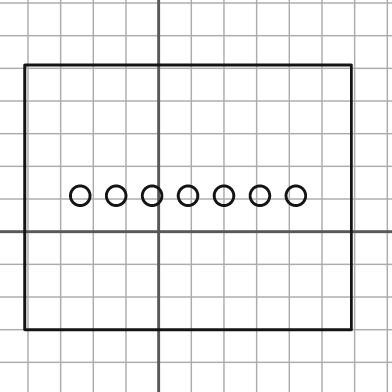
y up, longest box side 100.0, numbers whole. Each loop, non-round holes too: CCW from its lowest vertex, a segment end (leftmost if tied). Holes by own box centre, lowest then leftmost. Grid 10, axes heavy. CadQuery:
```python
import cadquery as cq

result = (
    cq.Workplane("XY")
    .moveTo(-41.0, -30.0)
    .lineTo(59.0, -30.0)
    .lineTo(59.0, 51.0)
    .lineTo(-41.0, 51.0)
    .close()
    .moveTo(-24.0, 11.0)
    .circle(3.0)
    .moveTo(-13.0, 11.0)
    .circle(3.0)
    .moveTo(-2.0, 11.0)
    .circle(3.0)
    .moveTo(9.0, 11.0)
    .circle(3.0)
    .moveTo(20.0, 11.0)
    .circle(3.0)
    .moveTo(31.0, 11.0)
    .circle(3.0)
    .moveTo(42.0, 11.0)
    .circle(3.0)
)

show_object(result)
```